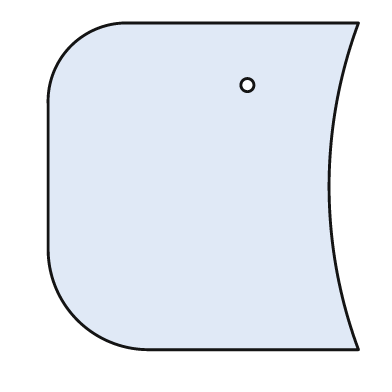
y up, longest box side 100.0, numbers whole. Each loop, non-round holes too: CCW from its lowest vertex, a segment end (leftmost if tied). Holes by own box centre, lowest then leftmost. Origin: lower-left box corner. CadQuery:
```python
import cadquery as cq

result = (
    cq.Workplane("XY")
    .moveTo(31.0, 0.0)
    .lineTo(95.0, 0.0)
    .threePointArc((86.0, 50.0), (95.0, 100.0))
    .lineTo(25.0, 100.0)
    .threePointArc((7.0, 93.0), (0.0, 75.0))
    .lineTo(0.0, 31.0)
    .threePointArc((9.0, 9.0), (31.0, 0.0))
    .close()
    .moveTo(61.0, 81.0)
    .circle(2.0)
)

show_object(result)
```